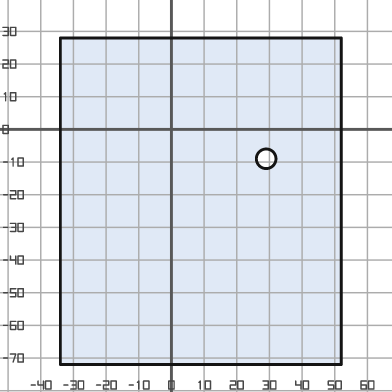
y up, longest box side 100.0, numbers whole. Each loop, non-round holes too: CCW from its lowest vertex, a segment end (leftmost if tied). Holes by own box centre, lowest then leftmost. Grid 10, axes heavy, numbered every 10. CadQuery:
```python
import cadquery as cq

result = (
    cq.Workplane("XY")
    .moveTo(-34.0, -72.0)
    .lineTo(52.0, -72.0)
    .lineTo(52.0, 28.0)
    .lineTo(-34.0, 28.0)
    .close()
    .moveTo(29.0, -9.0)
    .circle(3.0)
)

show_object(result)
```